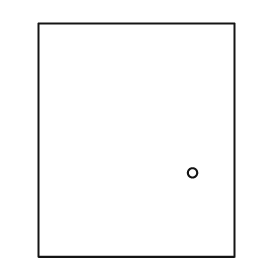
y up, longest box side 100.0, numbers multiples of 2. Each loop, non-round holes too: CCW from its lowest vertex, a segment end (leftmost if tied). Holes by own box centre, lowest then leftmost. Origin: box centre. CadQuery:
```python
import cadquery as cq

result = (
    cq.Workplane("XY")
    .moveTo(-42.0, -50.0)
    .lineTo(42.0, -50.0)
    .lineTo(42.0, 50.0)
    .lineTo(-42.0, 50.0)
    .close()
    .moveTo(24.0, -14.0)
    .circle(2.0)
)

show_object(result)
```